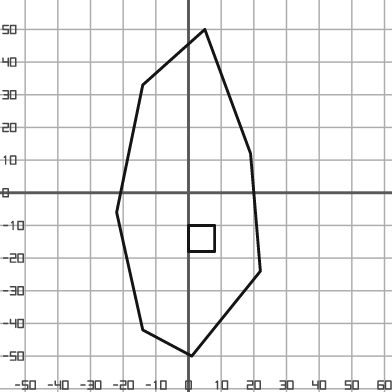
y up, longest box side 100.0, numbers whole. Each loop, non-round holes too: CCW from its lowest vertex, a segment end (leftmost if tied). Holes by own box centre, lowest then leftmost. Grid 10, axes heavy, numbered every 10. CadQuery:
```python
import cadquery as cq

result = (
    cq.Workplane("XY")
    .moveTo(1.0, -50.0)
    .lineTo(22.0, -24.0)
    .lineTo(19.0, 12.0)
    .lineTo(5.0, 50.0)
    .lineTo(-14.0, 33.0)
    .lineTo(-22.0, -6.0)
    .lineTo(-14.0, -42.0)
    .close()
    .moveTo(0.0, -18.0)
    .lineTo(8.0, -18.0)
    .lineTo(8.0, -10.0)
    .lineTo(0.0, -10.0)
    .close()
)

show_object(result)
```